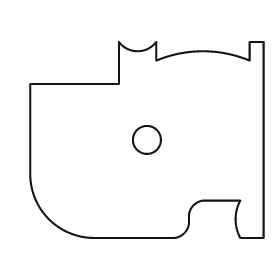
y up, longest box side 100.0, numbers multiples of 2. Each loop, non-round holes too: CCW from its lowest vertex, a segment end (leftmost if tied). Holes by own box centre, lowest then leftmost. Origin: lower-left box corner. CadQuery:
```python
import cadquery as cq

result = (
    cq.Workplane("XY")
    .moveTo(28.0, 0.0)
    .lineTo(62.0, 0.0)
    .threePointArc((66.0, 2.0), (68.0, 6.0))
    .lineTo(68.0, 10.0)
    .threePointArc((70.0, 14.0), (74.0, 16.0))
    .lineTo(90.0, 16.0)
    .threePointArc((88.0, 8.0), (90.0, 0.0))
    .lineTo(100.0, 0.0)
    .lineTo(100.0, 84.0)
    .lineTo(94.0, 84.0)
    .lineTo(94.0, 76.0)
    .threePointArc((74.0, 80.0), (54.0, 76.0))
    .lineTo(54.0, 84.0)
    .threePointArc((46.0, 80.0), (38.0, 84.0))
    .lineTo(38.0, 66.0)
    .lineTo(0.0, 66.0)
    .lineTo(0.0, 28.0)
    .threePointArc((8.0, 8.0), (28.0, 0.0))
    .close()
    .moveTo(50.0, 42.0)
    .circle(6.0)
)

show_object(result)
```